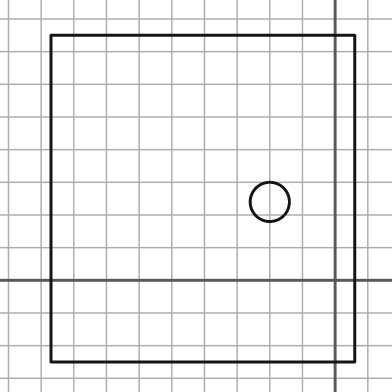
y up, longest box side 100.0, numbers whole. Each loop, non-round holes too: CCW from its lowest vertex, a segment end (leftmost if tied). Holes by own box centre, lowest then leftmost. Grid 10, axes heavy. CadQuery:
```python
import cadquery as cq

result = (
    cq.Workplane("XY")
    .moveTo(-87.0, -25.0)
    .lineTo(6.0, -25.0)
    .lineTo(6.0, 75.0)
    .lineTo(-87.0, 75.0)
    .close()
    .moveTo(-20.0, 24.0)
    .circle(6.0)
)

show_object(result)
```